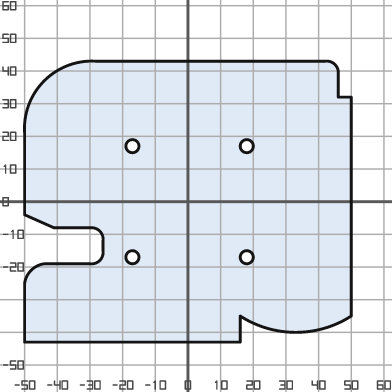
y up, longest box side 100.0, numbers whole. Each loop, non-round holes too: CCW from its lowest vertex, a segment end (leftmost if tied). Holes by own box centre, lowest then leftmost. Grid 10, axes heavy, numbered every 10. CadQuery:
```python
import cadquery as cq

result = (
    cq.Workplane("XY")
    .moveTo(-50.0, -43.0)
    .lineTo(16.0, -43.0)
    .lineTo(16.0, -35.0)
    .threePointArc((33.0, -40.0), (50.0, -35.0))
    .lineTo(50.0, 32.0)
    .lineTo(46.0, 32.0)
    .lineTo(46.0, 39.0)
    .threePointArc((45.0, 42.0), (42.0, 43.0))
    .lineTo(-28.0, 43.0)
    .threePointArc((-44.0, 37.0), (-50.0, 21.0))
    .lineTo(-50.0, -4.0)
    .lineTo(-41.0, -8.0)
    .lineTo(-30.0, -8.0)
    .threePointArc((-27.0, -9.0), (-26.0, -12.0))
    .lineTo(-26.0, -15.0)
    .threePointArc((-27.0, -18.0), (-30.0, -19.0))
    .lineTo(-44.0, -19.0)
    .threePointArc((-48.0, -21.0), (-50.0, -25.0))
    .close()
    .moveTo(-17.0, -17.0)
    .circle(2.0)
    .moveTo(18.0, -17.0)
    .circle(2.0)
    .moveTo(-17.0, 17.0)
    .circle(2.0)
    .moveTo(18.0, 17.0)
    .circle(2.0)
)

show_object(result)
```